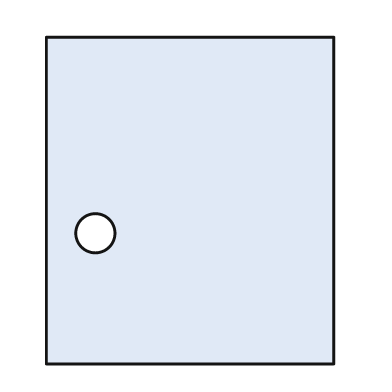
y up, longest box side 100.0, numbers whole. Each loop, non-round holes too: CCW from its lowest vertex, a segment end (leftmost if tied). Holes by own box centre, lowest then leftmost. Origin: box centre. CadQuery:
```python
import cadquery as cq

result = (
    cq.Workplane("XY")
    .moveTo(-44.0, -50.0)
    .lineTo(44.0, -50.0)
    .lineTo(44.0, 50.0)
    .lineTo(-44.0, 50.0)
    .close()
    .moveTo(-29.0, -10.0)
    .circle(6.0)
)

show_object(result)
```